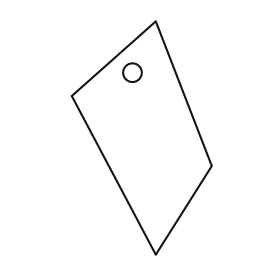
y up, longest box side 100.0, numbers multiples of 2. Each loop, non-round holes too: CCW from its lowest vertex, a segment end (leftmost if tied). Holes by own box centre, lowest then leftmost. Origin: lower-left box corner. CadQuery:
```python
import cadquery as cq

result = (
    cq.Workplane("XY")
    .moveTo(36.0, 0.0)
    .lineTo(60.0, 38.0)
    .lineTo(36.0, 100.0)
    .lineTo(0.0, 68.0)
    .close()
    .moveTo(26.0, 78.0)
    .circle(4.0)
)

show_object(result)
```